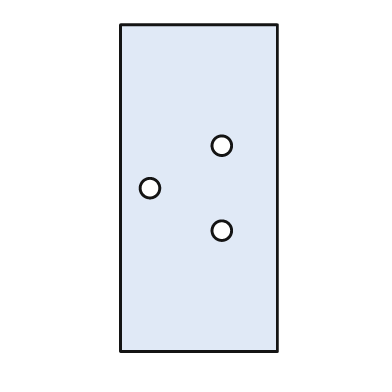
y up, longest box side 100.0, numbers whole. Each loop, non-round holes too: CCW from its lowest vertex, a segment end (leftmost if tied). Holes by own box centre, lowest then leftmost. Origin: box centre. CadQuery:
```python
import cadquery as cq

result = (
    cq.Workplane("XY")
    .moveTo(-24.0, -50.0)
    .lineTo(24.0, -50.0)
    .lineTo(24.0, 50.0)
    .lineTo(-24.0, 50.0)
    .close()
    .moveTo(7.0, -13.0)
    .circle(3.0)
    .moveTo(-15.0, 0.0)
    .circle(3.0)
    .moveTo(7.0, 13.0)
    .circle(3.0)
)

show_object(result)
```